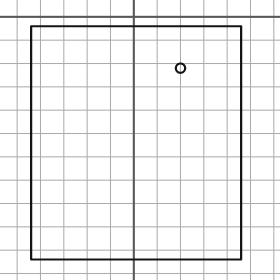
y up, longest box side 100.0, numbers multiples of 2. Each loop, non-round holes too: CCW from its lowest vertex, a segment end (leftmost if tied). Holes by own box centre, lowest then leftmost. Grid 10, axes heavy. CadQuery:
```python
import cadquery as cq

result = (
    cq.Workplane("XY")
    .moveTo(-44.0, -104.0)
    .lineTo(46.0, -104.0)
    .lineTo(46.0, -4.0)
    .lineTo(-44.0, -4.0)
    .close()
    .moveTo(20.0, -22.0)
    .circle(2.0)
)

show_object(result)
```